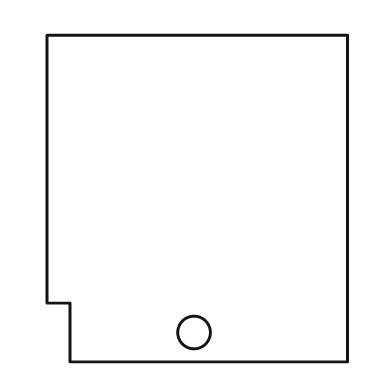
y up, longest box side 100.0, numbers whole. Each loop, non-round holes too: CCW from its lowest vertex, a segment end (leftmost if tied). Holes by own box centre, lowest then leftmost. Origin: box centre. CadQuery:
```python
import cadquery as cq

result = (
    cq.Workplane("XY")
    .moveTo(-39.0, -50.0)
    .lineTo(46.0, -50.0)
    .lineTo(46.0, 50.0)
    .lineTo(-46.0, 50.0)
    .lineTo(-46.0, -32.0)
    .lineTo(-39.0, -32.0)
    .close()
    .moveTo(-1.0, -41.0)
    .circle(5.0)
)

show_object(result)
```